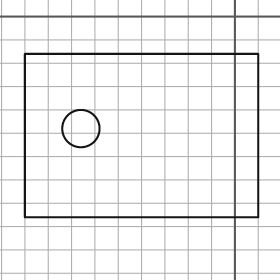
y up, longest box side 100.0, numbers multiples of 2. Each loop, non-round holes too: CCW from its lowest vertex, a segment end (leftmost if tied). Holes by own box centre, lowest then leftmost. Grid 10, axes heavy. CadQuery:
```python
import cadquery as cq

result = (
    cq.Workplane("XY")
    .moveTo(-90.0, -86.0)
    .lineTo(10.0, -86.0)
    .lineTo(10.0, -16.0)
    .lineTo(-90.0, -16.0)
    .close()
    .moveTo(-66.0, -48.0)
    .circle(8.0)
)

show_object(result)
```